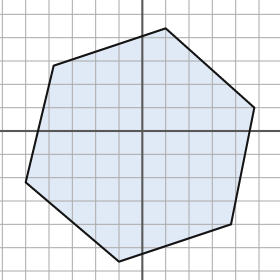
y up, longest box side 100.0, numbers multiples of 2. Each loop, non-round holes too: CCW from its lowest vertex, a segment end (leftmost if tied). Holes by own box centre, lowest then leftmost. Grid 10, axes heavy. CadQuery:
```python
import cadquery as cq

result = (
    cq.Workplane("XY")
    .moveTo(-10.0, -56.0)
    .lineTo(38.0, -40.0)
    .lineTo(48.0, 10.0)
    .lineTo(10.0, 44.0)
    .lineTo(-38.0, 28.0)
    .lineTo(-50.0, -22.0)
    .close()
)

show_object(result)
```